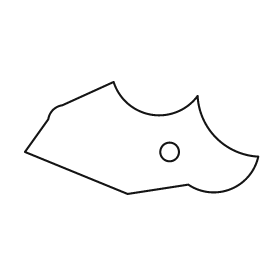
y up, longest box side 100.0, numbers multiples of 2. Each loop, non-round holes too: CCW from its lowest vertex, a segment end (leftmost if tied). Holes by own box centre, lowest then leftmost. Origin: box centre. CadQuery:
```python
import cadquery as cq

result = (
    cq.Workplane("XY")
    .moveTo(-6.0, -24.0)
    .lineTo(20.0, -20.0)
    .threePointArc((38.0, -22.0), (50.0, -8.0))
    .threePointArc((32.0, 0.0), (24.0, 18.0))
    .threePointArc((4.0, 10.0), (-12.0, 24.0))
    .lineTo(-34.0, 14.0)
    .threePointArc((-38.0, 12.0), (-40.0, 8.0))
    .lineTo(-50.0, -6.0)
    .close()
    .moveTo(12.0, -6.0)
    .circle(4.0)
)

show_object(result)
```